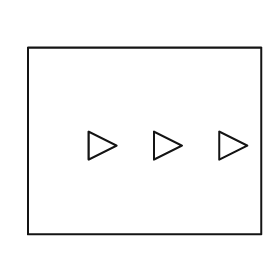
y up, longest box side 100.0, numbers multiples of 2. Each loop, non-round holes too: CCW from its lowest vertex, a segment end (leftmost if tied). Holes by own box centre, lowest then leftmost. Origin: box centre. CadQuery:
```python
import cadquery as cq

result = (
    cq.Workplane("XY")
    .moveTo(-50.0, -40.0)
    .lineTo(50.0, -40.0)
    .lineTo(50.0, 40.0)
    .lineTo(-50.0, 40.0)
    .close()
    .moveTo(-24.0, -8.0)
    .lineTo(-12.0, -2.0)
    .lineTo(-24.0, 4.0)
    .close()
    .moveTo(4.0, -8.0)
    .lineTo(16.0, -2.0)
    .lineTo(4.0, 4.0)
    .close()
    .moveTo(32.0, -8.0)
    .lineTo(44.0, -2.0)
    .lineTo(32.0, 4.0)
    .close()
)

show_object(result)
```